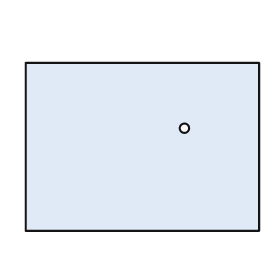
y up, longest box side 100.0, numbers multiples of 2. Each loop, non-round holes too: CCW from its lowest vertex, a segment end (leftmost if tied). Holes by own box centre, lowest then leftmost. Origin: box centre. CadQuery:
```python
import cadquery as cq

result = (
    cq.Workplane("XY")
    .moveTo(-50.0, -36.0)
    .lineTo(50.0, -36.0)
    .lineTo(50.0, 36.0)
    .lineTo(-50.0, 36.0)
    .close()
    .moveTo(18.0, 8.0)
    .circle(2.0)
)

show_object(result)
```